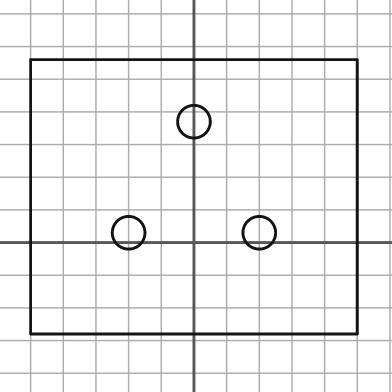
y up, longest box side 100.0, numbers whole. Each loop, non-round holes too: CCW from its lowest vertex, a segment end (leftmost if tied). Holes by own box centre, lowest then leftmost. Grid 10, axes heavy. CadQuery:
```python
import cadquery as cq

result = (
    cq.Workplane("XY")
    .moveTo(-50.0, -28.0)
    .lineTo(50.0, -28.0)
    .lineTo(50.0, 56.0)
    .lineTo(-50.0, 56.0)
    .close()
    .moveTo(-20.0, 3.0)
    .circle(5.0)
    .moveTo(20.0, 3.0)
    .circle(5.0)
    .moveTo(0.0, 37.0)
    .circle(5.0)
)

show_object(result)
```